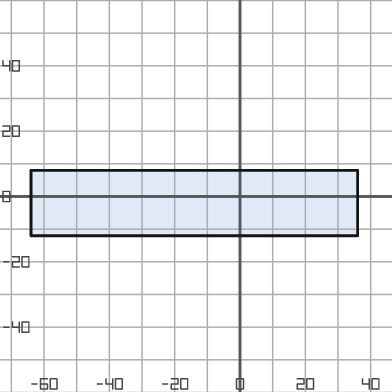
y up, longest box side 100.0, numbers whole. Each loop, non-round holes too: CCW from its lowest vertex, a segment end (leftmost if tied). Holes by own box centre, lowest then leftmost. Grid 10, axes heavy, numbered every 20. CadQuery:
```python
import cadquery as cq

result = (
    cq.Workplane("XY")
    .moveTo(-64.0, -12.0)
    .lineTo(36.0, -12.0)
    .lineTo(36.0, 8.0)
    .lineTo(-64.0, 8.0)
    .close()
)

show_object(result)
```